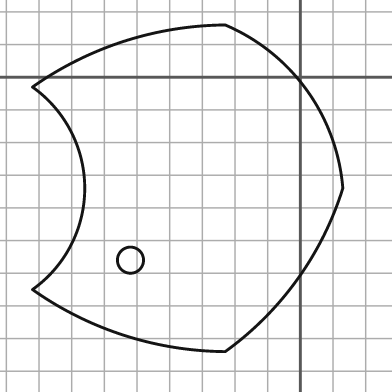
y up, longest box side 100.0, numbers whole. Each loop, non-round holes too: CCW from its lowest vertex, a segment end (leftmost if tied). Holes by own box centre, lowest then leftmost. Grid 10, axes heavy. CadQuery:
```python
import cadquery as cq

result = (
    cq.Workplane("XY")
    .moveTo(-23.0, -84.0)
    .threePointArc((-1.0, -62.0), (13.0, -34.0))
    .threePointArc((2.0, -4.0), (-23.0, 16.0))
    .threePointArc((-54.0, 11.0), (-82.0, -3.0))
    .threePointArc((-66.0, -34.0), (-82.0, -65.0))
    .threePointArc((-54.0, -79.0), (-23.0, -84.0))
    .close()
    .moveTo(-52.0, -56.0)
    .circle(4.0)
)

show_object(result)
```